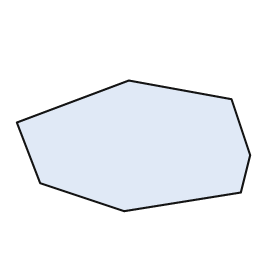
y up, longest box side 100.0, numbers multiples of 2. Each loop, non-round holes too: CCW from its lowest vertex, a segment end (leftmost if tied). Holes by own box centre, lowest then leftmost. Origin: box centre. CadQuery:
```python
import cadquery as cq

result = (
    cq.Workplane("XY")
    .moveTo(-4.0, -28.0)
    .lineTo(46.0, -20.0)
    .lineTo(50.0, -4.0)
    .lineTo(42.0, 20.0)
    .lineTo(-2.0, 28.0)
    .lineTo(-50.0, 10.0)
    .lineTo(-40.0, -16.0)
    .close()
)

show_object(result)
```